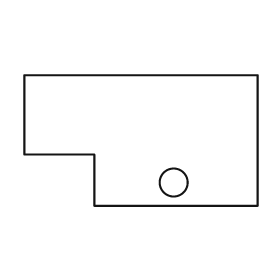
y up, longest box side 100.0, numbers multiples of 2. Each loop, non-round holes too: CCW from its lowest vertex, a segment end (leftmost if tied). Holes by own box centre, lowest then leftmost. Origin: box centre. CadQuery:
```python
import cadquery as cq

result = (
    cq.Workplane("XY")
    .moveTo(-20.0, -28.0)
    .lineTo(50.0, -28.0)
    .lineTo(50.0, 28.0)
    .lineTo(-50.0, 28.0)
    .lineTo(-50.0, -6.0)
    .lineTo(-20.0, -6.0)
    .close()
    .moveTo(14.0, -18.0)
    .circle(6.0)
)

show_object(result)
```